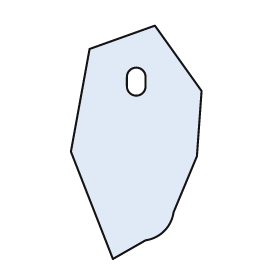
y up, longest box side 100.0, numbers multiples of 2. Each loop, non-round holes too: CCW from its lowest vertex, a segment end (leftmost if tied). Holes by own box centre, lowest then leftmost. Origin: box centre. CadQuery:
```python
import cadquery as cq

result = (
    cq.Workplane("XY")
    .moveTo(-10.0, -50.0)
    .lineTo(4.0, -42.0)
    .threePointArc((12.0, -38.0), (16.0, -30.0))
    .lineTo(26.0, -6.0)
    .lineTo(28.0, 22.0)
    .lineTo(8.0, 50.0)
    .lineTo(-20.0, 40.0)
    .lineTo(-28.0, -4.0)
    .close()
    .moveTo(-4.0, 24.0)
    .threePointArc((0.0, 20.0), (4.0, 24.0))
    .lineTo(4.0, 28.0)
    .threePointArc((0.0, 32.0), (-4.0, 28.0))
    .close()
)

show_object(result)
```